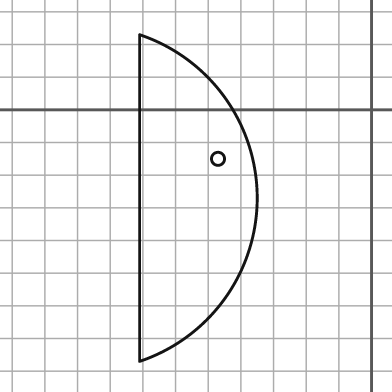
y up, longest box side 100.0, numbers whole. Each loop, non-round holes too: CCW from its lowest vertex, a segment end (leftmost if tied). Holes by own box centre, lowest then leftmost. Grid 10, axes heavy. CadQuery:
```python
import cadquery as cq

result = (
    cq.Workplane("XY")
    .moveTo(-71.0, -77.0)
    .threePointArc((-35.0, -27.0), (-71.0, 23.0))
    .close()
    .moveTo(-47.0, -15.0)
    .circle(2.0)
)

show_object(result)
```